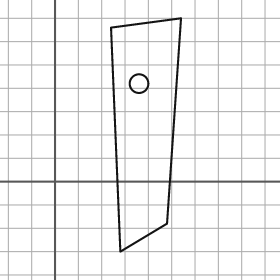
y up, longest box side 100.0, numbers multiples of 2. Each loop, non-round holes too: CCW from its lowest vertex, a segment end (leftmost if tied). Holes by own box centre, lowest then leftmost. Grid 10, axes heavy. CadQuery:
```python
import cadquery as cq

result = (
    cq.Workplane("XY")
    .moveTo(28.0, -30.0)
    .lineTo(48.0, -18.0)
    .lineTo(54.0, 70.0)
    .lineTo(24.0, 66.0)
    .close()
    .moveTo(36.0, 42.0)
    .circle(4.0)
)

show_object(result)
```